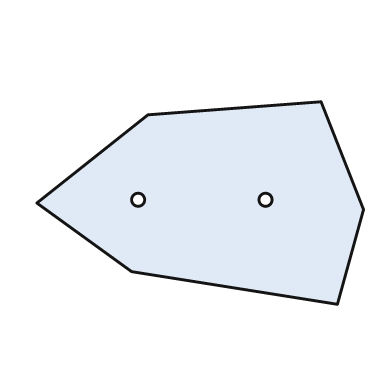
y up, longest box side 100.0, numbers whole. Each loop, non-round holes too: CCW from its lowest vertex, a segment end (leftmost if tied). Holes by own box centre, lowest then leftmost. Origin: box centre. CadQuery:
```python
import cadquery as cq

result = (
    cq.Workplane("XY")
    .moveTo(42.0, -31.0)
    .lineTo(50.0, -2.0)
    .lineTo(37.0, 31.0)
    .lineTo(-16.0, 27.0)
    .lineTo(-50.0, 0.0)
    .lineTo(-21.0, -21.0)
    .close()
    .moveTo(-19.0, 1.0)
    .circle(2.0)
    .moveTo(20.0, 1.0)
    .circle(2.0)
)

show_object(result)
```